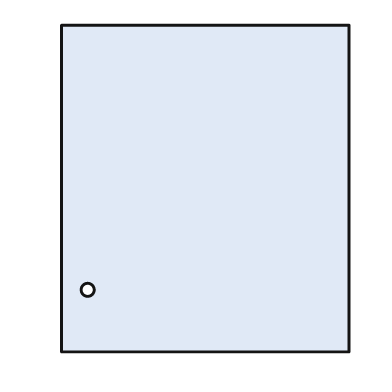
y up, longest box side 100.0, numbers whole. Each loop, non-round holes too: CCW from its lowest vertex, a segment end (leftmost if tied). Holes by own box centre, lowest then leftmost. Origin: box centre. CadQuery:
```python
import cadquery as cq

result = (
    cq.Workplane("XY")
    .moveTo(-44.0, -50.0)
    .lineTo(44.0, -50.0)
    .lineTo(44.0, 50.0)
    .lineTo(-44.0, 50.0)
    .close()
    .moveTo(-36.0, -31.0)
    .circle(2.0)
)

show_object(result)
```